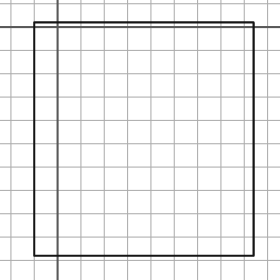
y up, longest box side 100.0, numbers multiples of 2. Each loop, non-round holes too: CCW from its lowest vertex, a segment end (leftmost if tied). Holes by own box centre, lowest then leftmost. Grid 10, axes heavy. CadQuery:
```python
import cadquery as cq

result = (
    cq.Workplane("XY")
    .moveTo(-10.0, -98.0)
    .lineTo(84.0, -98.0)
    .lineTo(84.0, 2.0)
    .lineTo(-10.0, 2.0)
    .close()
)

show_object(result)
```